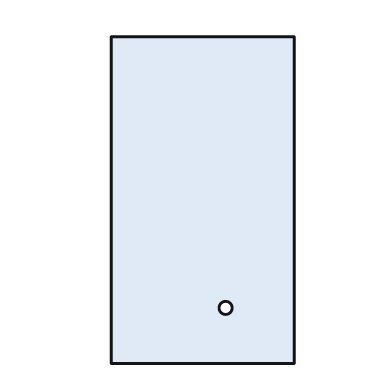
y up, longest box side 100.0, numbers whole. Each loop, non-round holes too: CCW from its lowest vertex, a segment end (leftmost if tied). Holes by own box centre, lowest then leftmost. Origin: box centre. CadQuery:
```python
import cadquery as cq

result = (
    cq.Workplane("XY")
    .moveTo(-28.0, -50.0)
    .lineTo(28.0, -50.0)
    .lineTo(28.0, 50.0)
    .lineTo(-28.0, 50.0)
    .close()
    .moveTo(7.0, -33.0)
    .circle(2.0)
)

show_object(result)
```